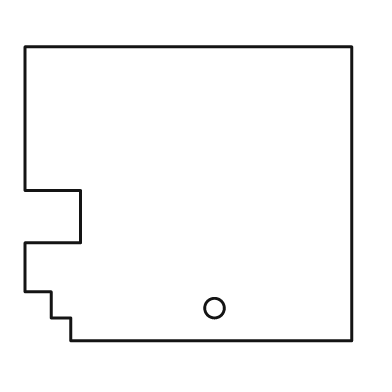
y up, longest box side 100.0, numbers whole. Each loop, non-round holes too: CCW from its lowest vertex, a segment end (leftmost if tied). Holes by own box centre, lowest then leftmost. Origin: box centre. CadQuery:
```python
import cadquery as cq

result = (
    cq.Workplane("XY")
    .moveTo(-36.0, -45.0)
    .lineTo(50.0, -45.0)
    .lineTo(50.0, 45.0)
    .lineTo(-50.0, 45.0)
    .lineTo(-50.0, 1.0)
    .lineTo(-33.0, 1.0)
    .lineTo(-33.0, -15.0)
    .lineTo(-50.0, -15.0)
    .lineTo(-50.0, -30.0)
    .lineTo(-42.0, -30.0)
    .lineTo(-42.0, -38.0)
    .lineTo(-36.0, -38.0)
    .close()
    .moveTo(8.0, -35.0)
    .circle(3.0)
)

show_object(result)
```